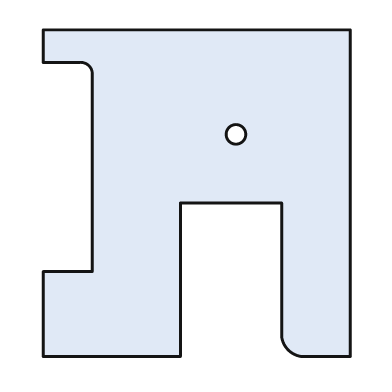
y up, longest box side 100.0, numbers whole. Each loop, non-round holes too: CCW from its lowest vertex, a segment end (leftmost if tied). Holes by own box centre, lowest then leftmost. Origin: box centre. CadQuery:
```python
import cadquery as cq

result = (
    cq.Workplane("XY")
    .moveTo(-47.0, -50.0)
    .lineTo(-5.0, -50.0)
    .lineTo(-5.0, -3.0)
    .lineTo(26.0, -3.0)
    .lineTo(26.0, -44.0)
    .threePointArc((28.0, -48.0), (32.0, -50.0))
    .lineTo(47.0, -50.0)
    .lineTo(47.0, 50.0)
    .lineTo(-47.0, 50.0)
    .lineTo(-47.0, 40.0)
    .lineTo(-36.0, 40.0)
    .threePointArc((-33.0, 39.0), (-32.0, 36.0))
    .lineTo(-32.0, -24.0)
    .lineTo(-47.0, -24.0)
    .close()
    .moveTo(12.0, 18.0)
    .circle(3.0)
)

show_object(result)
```